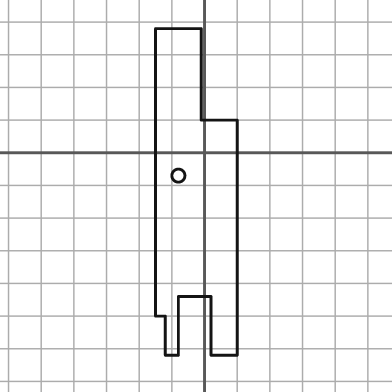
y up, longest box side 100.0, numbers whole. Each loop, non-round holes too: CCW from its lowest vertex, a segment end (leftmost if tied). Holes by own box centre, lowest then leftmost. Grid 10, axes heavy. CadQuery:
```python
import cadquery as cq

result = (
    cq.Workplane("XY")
    .moveTo(-12.0, -62.0)
    .lineTo(-8.0, -62.0)
    .lineTo(-8.0, -44.0)
    .lineTo(2.0, -44.0)
    .lineTo(2.0, -62.0)
    .lineTo(10.0, -62.0)
    .lineTo(10.0, 10.0)
    .lineTo(-1.0, 10.0)
    .lineTo(-1.0, 38.0)
    .lineTo(-15.0, 38.0)
    .lineTo(-15.0, -50.0)
    .lineTo(-12.0, -50.0)
    .close()
    .moveTo(-8.0, -7.0)
    .circle(2.0)
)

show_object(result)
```